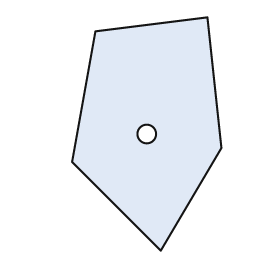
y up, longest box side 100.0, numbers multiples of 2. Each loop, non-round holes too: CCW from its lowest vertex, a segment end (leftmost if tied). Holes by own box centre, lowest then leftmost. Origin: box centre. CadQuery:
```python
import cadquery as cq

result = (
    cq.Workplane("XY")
    .moveTo(6.0, -50.0)
    .lineTo(32.0, -6.0)
    .lineTo(26.0, 50.0)
    .lineTo(-22.0, 44.0)
    .lineTo(-32.0, -12.0)
    .close()
    .moveTo(0.0, 0.0)
    .circle(4.0)
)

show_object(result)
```